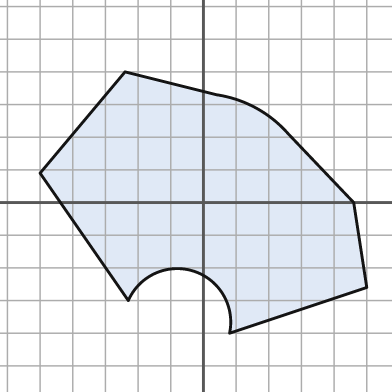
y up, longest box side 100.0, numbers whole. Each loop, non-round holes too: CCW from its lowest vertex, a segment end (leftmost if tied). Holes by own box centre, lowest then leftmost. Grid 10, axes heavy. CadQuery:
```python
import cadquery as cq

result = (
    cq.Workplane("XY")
    .moveTo(8.0, -40.0)
    .lineTo(50.0, -26.0)
    .lineTo(46.0, 0.0)
    .lineTo(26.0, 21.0)
    .threePointArc((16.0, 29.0), (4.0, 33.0))
    .lineTo(-24.0, 40.0)
    .lineTo(-50.0, 9.0)
    .lineTo(-23.0, -30.0)
    .threePointArc((-3.0, -21.0), (8.0, -40.0))
    .close()
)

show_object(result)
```